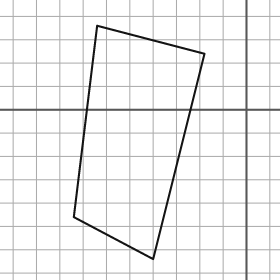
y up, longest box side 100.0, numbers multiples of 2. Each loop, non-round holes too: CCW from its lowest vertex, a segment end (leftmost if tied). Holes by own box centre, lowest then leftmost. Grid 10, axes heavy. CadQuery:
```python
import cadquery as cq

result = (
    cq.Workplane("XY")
    .moveTo(-40.0, -64.0)
    .lineTo(-18.0, 24.0)
    .lineTo(-64.0, 36.0)
    .lineTo(-74.0, -46.0)
    .close()
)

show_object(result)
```